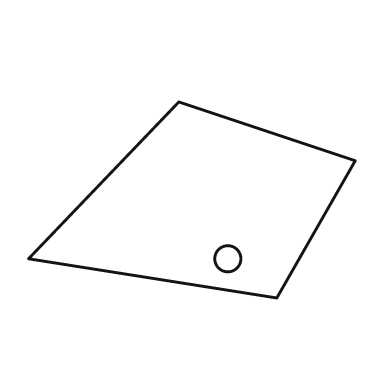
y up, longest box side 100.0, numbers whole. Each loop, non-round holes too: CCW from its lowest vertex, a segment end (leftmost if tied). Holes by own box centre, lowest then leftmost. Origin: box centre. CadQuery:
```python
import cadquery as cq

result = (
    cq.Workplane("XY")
    .moveTo(26.0, -30.0)
    .lineTo(50.0, 12.0)
    .lineTo(-4.0, 30.0)
    .lineTo(-50.0, -18.0)
    .close()
    .moveTo(11.0, -18.0)
    .circle(4.0)
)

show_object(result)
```